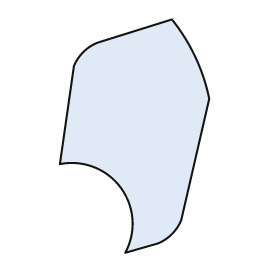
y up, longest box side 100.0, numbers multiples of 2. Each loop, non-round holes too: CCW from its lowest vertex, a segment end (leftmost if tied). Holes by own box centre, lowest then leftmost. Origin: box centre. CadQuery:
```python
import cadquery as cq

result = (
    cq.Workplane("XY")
    .moveTo(-4.0, -50.0)
    .lineTo(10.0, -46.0)
    .threePointArc((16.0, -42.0), (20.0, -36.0))
    .lineTo(32.0, 16.0)
    .threePointArc((26.0, 34.0), (16.0, 50.0))
    .lineTo(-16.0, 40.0)
    .threePointArc((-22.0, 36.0), (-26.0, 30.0))
    .lineTo(-32.0, -12.0)
    .threePointArc((-6.0, -22.0), (-4.0, -50.0))
    .close()
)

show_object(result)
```